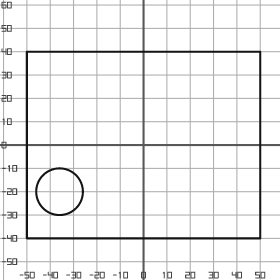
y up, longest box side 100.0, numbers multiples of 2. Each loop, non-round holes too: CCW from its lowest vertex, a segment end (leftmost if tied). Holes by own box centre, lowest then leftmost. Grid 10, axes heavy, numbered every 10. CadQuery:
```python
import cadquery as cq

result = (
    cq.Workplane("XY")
    .moveTo(-50.0, -40.0)
    .lineTo(50.0, -40.0)
    .lineTo(50.0, 40.0)
    .lineTo(-50.0, 40.0)
    .close()
    .moveTo(-36.0, -20.0)
    .circle(10.0)
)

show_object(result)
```